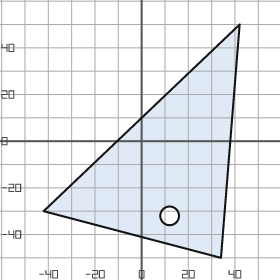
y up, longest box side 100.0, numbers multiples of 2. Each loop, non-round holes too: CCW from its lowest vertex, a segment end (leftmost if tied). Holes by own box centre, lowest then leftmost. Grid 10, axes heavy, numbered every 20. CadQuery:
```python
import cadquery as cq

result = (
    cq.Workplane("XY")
    .moveTo(34.0, -50.0)
    .lineTo(42.0, 50.0)
    .lineTo(-42.0, -30.0)
    .close()
    .moveTo(12.0, -32.0)
    .circle(4.0)
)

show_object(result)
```